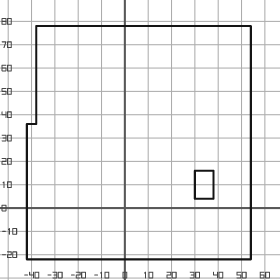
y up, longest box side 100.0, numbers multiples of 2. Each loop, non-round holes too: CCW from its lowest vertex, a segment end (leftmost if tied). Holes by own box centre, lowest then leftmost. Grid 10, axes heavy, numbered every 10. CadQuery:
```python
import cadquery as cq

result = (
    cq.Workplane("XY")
    .moveTo(-42.0, -22.0)
    .lineTo(54.0, -22.0)
    .lineTo(54.0, 78.0)
    .lineTo(-38.0, 78.0)
    .lineTo(-38.0, 36.0)
    .lineTo(-42.0, 36.0)
    .close()
    .moveTo(30.0, 4.0)
    .lineTo(38.0, 4.0)
    .lineTo(38.0, 16.0)
    .lineTo(30.0, 16.0)
    .close()
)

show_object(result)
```